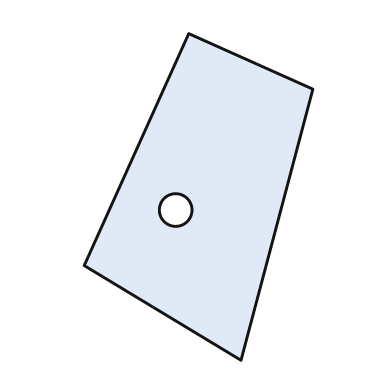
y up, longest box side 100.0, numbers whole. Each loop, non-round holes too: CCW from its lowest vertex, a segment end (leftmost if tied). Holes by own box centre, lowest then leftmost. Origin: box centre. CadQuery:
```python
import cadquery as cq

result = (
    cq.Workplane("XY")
    .moveTo(13.0, -50.0)
    .lineTo(35.0, 33.0)
    .lineTo(-3.0, 50.0)
    .lineTo(-35.0, -21.0)
    .close()
    .moveTo(-7.0, -4.0)
    .circle(5.0)
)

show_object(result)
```